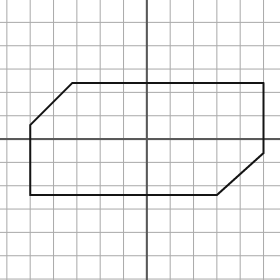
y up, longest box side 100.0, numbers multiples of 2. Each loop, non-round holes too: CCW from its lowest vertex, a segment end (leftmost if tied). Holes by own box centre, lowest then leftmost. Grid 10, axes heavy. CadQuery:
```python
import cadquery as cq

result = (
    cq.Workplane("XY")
    .moveTo(-50.0, -24.0)
    .lineTo(30.0, -24.0)
    .lineTo(50.0, -6.0)
    .lineTo(50.0, 24.0)
    .lineTo(-32.0, 24.0)
    .lineTo(-50.0, 6.0)
    .close()
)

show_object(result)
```